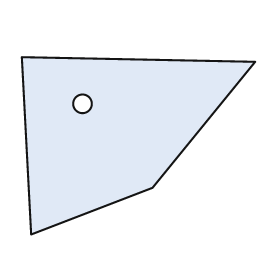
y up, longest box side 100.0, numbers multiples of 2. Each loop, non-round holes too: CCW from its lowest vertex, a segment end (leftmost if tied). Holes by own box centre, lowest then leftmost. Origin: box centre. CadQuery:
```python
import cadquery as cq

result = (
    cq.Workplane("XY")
    .moveTo(-46.0, -38.0)
    .lineTo(6.0, -18.0)
    .lineTo(50.0, 36.0)
    .lineTo(-50.0, 38.0)
    .close()
    .moveTo(-24.0, 18.0)
    .circle(4.0)
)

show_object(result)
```